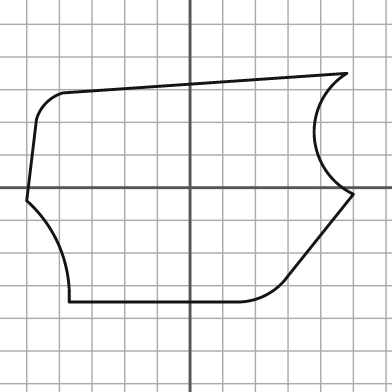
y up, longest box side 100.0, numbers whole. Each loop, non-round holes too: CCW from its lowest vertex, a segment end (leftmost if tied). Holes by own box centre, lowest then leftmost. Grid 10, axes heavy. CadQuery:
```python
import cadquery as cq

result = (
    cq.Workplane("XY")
    .moveTo(-37.0, -35.0)
    .lineTo(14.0, -35.0)
    .threePointArc((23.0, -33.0), (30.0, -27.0))
    .lineTo(50.0, -2.0)
    .threePointArc((38.0, 16.0), (48.0, 35.0))
    .lineTo(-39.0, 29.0)
    .threePointArc((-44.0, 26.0), (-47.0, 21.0))
    .lineTo(-50.0, -4.0)
    .threePointArc((-40.0, -18.0), (-37.0, -35.0))
    .close()
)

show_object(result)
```